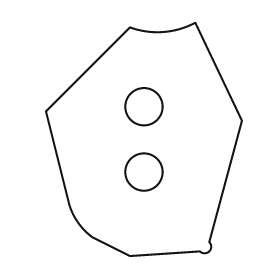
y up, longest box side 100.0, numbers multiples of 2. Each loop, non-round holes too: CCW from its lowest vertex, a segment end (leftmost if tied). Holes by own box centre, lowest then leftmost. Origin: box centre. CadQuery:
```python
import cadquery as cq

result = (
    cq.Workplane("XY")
    .moveTo(-6.0, -50.0)
    .lineTo(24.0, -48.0)
    .threePointArc((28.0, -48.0), (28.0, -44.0))
    .lineTo(42.0, 8.0)
    .lineTo(22.0, 50.0)
    .threePointArc((8.0, 46.0), (-6.0, 48.0))
    .lineTo(-42.0, 12.0)
    .lineTo(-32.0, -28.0)
    .threePointArc((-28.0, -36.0), (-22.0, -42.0))
    .close()
    .moveTo(0.0, -14.0)
    .circle(8.0)
    .moveTo(0.0, 14.0)
    .circle(8.0)
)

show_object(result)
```